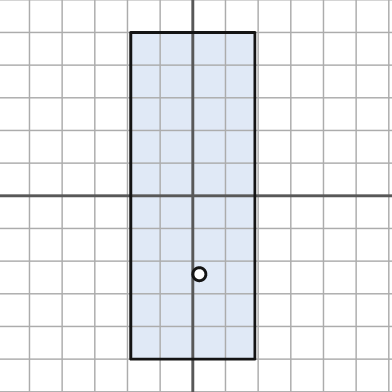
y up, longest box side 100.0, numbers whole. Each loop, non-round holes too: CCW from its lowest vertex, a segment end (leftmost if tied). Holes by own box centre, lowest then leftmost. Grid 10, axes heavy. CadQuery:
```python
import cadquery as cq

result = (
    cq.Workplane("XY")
    .moveTo(-19.0, -50.0)
    .lineTo(19.0, -50.0)
    .lineTo(19.0, 50.0)
    .lineTo(-19.0, 50.0)
    .close()
    .moveTo(2.0, -24.0)
    .circle(2.0)
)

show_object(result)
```